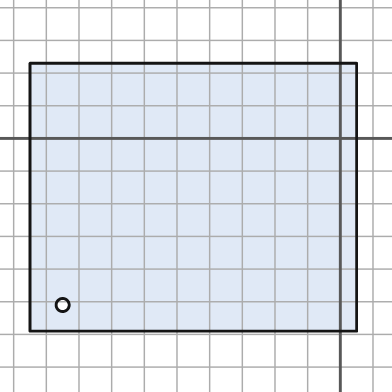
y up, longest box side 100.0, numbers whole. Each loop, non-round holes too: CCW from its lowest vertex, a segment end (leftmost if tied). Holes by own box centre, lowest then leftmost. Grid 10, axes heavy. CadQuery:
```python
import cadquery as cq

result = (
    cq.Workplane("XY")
    .moveTo(-95.0, -59.0)
    .lineTo(5.0, -59.0)
    .lineTo(5.0, 23.0)
    .lineTo(-95.0, 23.0)
    .close()
    .moveTo(-85.0, -51.0)
    .circle(2.0)
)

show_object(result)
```